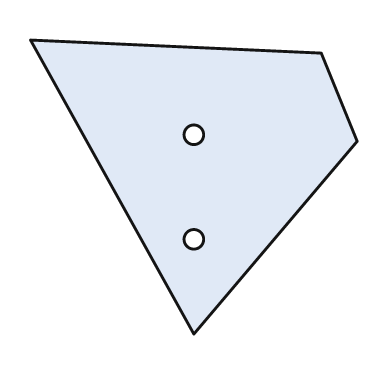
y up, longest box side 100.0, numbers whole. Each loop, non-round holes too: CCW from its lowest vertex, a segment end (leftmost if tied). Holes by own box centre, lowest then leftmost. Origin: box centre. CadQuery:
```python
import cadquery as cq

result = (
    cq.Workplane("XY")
    .moveTo(0.0, -45.0)
    .lineTo(50.0, 14.0)
    .lineTo(39.0, 41.0)
    .lineTo(-50.0, 45.0)
    .close()
    .moveTo(0.0, -16.0)
    .circle(3.0)
    .moveTo(0.0, 16.0)
    .circle(3.0)
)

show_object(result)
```